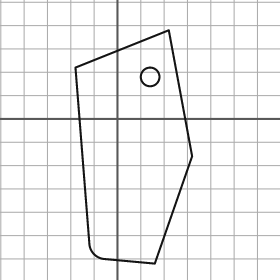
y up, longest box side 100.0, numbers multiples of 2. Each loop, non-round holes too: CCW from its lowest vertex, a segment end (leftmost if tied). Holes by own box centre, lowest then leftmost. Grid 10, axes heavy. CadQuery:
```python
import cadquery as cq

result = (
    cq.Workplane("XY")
    .moveTo(16.0, -62.0)
    .lineTo(32.0, -16.0)
    .lineTo(22.0, 38.0)
    .lineTo(-18.0, 22.0)
    .lineTo(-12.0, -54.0)
    .threePointArc((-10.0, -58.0), (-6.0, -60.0))
    .close()
    .moveTo(14.0, 18.0)
    .circle(4.0)
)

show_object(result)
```